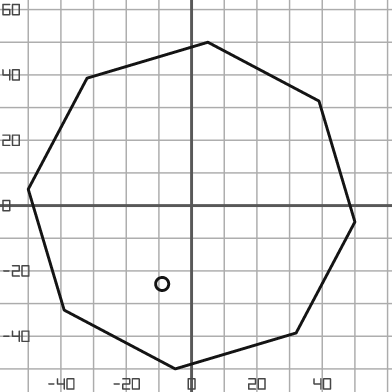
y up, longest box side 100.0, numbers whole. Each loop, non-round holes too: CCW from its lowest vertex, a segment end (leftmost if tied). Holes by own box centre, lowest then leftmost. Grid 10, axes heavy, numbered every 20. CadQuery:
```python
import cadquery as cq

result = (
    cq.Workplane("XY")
    .moveTo(-5.0, -50.0)
    .lineTo(32.0, -39.0)
    .lineTo(50.0, -5.0)
    .lineTo(39.0, 32.0)
    .lineTo(5.0, 50.0)
    .lineTo(-32.0, 39.0)
    .lineTo(-50.0, 5.0)
    .lineTo(-39.0, -32.0)
    .close()
    .moveTo(-9.0, -24.0)
    .circle(2.0)
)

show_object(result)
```